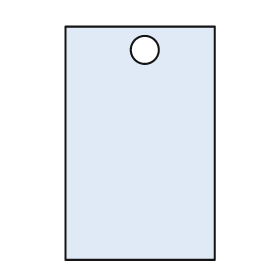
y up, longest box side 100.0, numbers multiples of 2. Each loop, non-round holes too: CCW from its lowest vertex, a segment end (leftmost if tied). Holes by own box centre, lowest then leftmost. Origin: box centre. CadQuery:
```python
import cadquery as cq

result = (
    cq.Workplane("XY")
    .moveTo(-32.0, -50.0)
    .lineTo(32.0, -50.0)
    .lineTo(32.0, 50.0)
    .lineTo(-32.0, 50.0)
    .close()
    .moveTo(2.0, 40.0)
    .circle(6.0)
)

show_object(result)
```